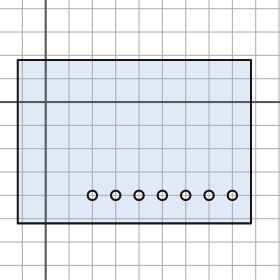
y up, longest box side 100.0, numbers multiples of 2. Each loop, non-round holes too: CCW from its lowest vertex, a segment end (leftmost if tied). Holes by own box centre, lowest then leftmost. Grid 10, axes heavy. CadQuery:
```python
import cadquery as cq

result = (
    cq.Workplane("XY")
    .moveTo(-12.0, -52.0)
    .lineTo(88.0, -52.0)
    .lineTo(88.0, 18.0)
    .lineTo(-12.0, 18.0)
    .close()
    .moveTo(20.0, -40.0)
    .circle(2.0)
    .moveTo(30.0, -40.0)
    .circle(2.0)
    .moveTo(40.0, -40.0)
    .circle(2.0)
    .moveTo(50.0, -40.0)
    .circle(2.0)
    .moveTo(60.0, -40.0)
    .circle(2.0)
    .moveTo(70.0, -40.0)
    .circle(2.0)
    .moveTo(80.0, -40.0)
    .circle(2.0)
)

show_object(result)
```